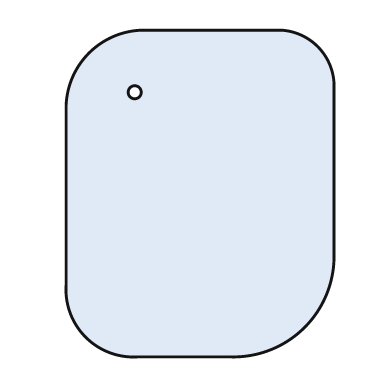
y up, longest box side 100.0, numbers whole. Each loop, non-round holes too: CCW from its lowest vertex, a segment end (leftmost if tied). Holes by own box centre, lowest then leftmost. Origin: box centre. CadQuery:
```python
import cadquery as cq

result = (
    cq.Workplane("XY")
    .moveTo(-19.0, -50.0)
    .lineTo(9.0, -50.0)
    .threePointArc((32.0, -41.0), (41.0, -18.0))
    .lineTo(41.0, 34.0)
    .threePointArc((36.0, 45.0), (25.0, 50.0))
    .lineTo(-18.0, 50.0)
    .threePointArc((-34.0, 43.0), (-41.0, 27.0))
    .lineTo(-41.0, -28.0)
    .threePointArc((-35.0, -44.0), (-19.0, -50.0))
    .close()
    .moveTo(-20.0, 31.0)
    .circle(2.0)
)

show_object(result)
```